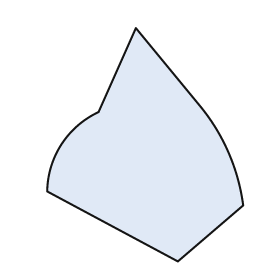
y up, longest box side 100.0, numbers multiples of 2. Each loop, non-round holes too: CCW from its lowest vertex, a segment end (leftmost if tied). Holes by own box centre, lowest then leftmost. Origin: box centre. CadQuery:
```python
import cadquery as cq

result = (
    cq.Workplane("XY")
    .moveTo(14.0, -50.0)
    .lineTo(42.0, -26.0)
    .threePointArc((36.0, -4.0), (24.0, 16.0))
    .lineTo(-4.0, 50.0)
    .lineTo(-20.0, 14.0)
    .threePointArc((-36.0, 0.0), (-42.0, -20.0))
    .close()
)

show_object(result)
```